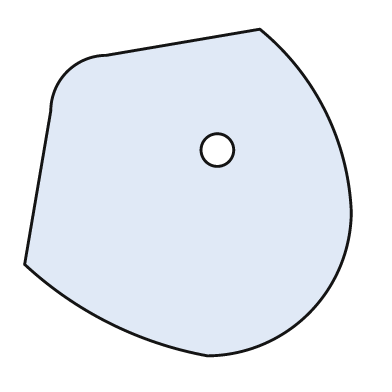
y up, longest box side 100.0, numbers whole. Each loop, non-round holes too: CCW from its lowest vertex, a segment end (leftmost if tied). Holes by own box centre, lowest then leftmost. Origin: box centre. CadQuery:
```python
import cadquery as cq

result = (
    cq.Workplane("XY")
    .moveTo(6.0, -50.0)
    .threePointArc((37.0, -37.0), (50.0, -6.0))
    .threePointArc((42.0, 25.0), (22.0, 50.0))
    .lineTo(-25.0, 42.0)
    .threePointArc((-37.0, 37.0), (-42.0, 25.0))
    .lineTo(-50.0, -22.0)
    .threePointArc((-24.0, -40.0), (6.0, -50.0))
    .close()
    .moveTo(9.0, 13.0)
    .circle(5.0)
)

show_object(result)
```